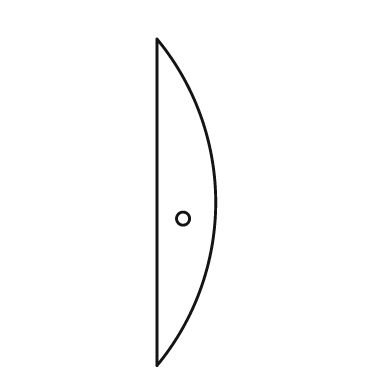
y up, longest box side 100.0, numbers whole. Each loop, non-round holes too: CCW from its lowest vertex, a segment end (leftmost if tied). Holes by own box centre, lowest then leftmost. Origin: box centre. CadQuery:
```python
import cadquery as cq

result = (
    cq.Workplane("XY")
    .moveTo(-9.0, -50.0)
    .threePointArc((9.0, 0.0), (-9.0, 50.0))
    .close()
    .moveTo(-1.0, -5.0)
    .circle(2.0)
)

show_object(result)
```